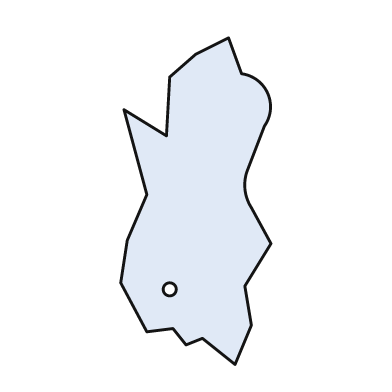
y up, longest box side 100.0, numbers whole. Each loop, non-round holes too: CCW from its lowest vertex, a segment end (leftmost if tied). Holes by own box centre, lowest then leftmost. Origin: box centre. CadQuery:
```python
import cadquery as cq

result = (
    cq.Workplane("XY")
    .moveTo(12.0, -50.0)
    .lineTo(17.0, -38.0)
    .lineTo(15.0, -26.0)
    .lineTo(23.0, -13.0)
    .lineTo(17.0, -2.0)
    .threePointArc((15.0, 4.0), (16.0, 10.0))
    .lineTo(21.0, 23.0)
    .threePointArc((22.0, 33.0), (14.0, 39.0))
    .lineTo(10.0, 50.0)
    .lineTo(0.0, 45.0)
    .lineTo(-8.0, 38.0)
    .lineTo(-9.0, 20.0)
    .lineTo(-22.0, 28.0)
    .lineTo(-15.0, 2.0)
    .lineTo(-21.0, -12.0)
    .lineTo(-23.0, -25.0)
    .lineTo(-15.0, -40.0)
    .lineTo(-7.0, -39.0)
    .lineTo(-3.0, -44.0)
    .lineTo(2.0, -42.0)
    .close()
    .moveTo(-8.0, -27.0)
    .circle(2.0)
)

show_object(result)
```